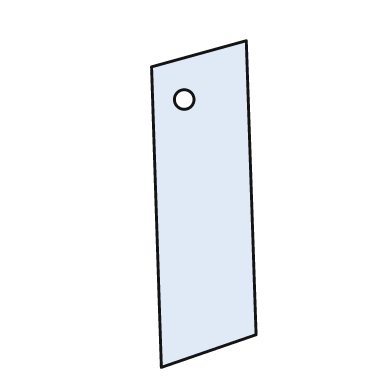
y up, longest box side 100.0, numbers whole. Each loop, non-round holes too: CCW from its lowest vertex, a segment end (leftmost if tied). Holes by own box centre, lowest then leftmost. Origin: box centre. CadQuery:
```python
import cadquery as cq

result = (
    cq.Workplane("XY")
    .moveTo(-13.0, -50.0)
    .lineTo(16.0, -40.0)
    .lineTo(13.0, 50.0)
    .lineTo(-16.0, 42.0)
    .close()
    .moveTo(-6.0, 32.0)
    .circle(3.0)
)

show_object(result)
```